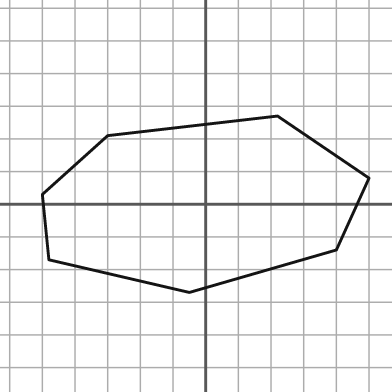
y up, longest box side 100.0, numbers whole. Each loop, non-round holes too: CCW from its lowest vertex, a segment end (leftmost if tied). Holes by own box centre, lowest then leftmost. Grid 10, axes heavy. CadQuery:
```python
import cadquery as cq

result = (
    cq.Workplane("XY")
    .moveTo(-5.0, -27.0)
    .lineTo(40.0, -14.0)
    .lineTo(50.0, 8.0)
    .lineTo(22.0, 27.0)
    .lineTo(-30.0, 21.0)
    .lineTo(-50.0, 3.0)
    .lineTo(-48.0, -17.0)
    .close()
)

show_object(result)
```